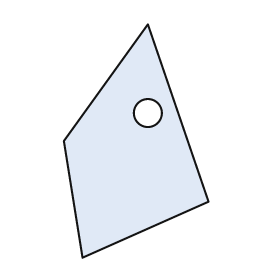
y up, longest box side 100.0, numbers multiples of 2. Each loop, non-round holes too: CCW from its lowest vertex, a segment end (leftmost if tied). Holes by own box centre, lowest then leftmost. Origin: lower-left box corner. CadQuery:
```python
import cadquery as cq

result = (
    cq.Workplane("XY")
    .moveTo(8.0, 0.0)
    .lineTo(62.0, 24.0)
    .lineTo(36.0, 100.0)
    .lineTo(0.0, 50.0)
    .close()
    .moveTo(36.0, 62.0)
    .circle(6.0)
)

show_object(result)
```